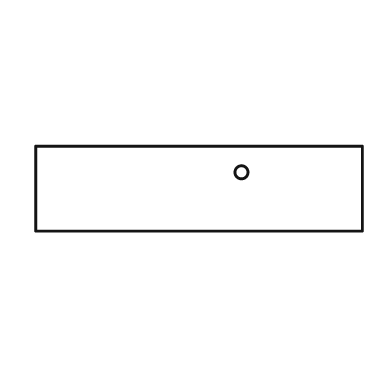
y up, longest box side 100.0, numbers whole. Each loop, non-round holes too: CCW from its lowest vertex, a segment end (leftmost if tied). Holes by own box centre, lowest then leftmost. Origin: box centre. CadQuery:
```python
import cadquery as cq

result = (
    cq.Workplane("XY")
    .moveTo(-50.0, -13.0)
    .lineTo(50.0, -13.0)
    .lineTo(50.0, 13.0)
    .lineTo(-50.0, 13.0)
    .close()
    .moveTo(13.0, 5.0)
    .circle(2.0)
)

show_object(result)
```